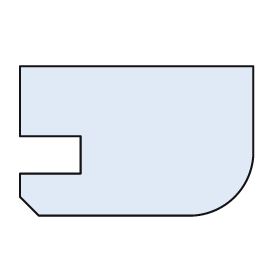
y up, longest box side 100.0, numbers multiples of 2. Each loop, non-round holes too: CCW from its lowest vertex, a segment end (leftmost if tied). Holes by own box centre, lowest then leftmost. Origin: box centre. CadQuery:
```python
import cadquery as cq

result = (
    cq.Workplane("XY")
    .moveTo(-42.0, -32.0)
    .lineTo(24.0, -32.0)
    .threePointArc((42.0, -24.0), (50.0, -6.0))
    .lineTo(50.0, 32.0)
    .lineTo(-50.0, 32.0)
    .lineTo(-50.0, 2.0)
    .lineTo(-24.0, 2.0)
    .lineTo(-24.0, -14.0)
    .lineTo(-50.0, -14.0)
    .lineTo(-50.0, -24.0)
    .close()
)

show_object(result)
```